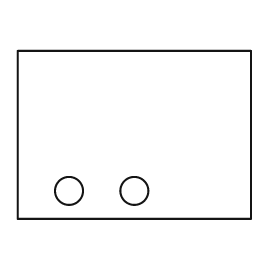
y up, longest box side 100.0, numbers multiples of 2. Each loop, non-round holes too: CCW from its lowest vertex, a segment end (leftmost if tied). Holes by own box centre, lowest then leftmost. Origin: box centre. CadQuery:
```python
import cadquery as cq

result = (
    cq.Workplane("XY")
    .moveTo(-50.0, -36.0)
    .lineTo(50.0, -36.0)
    .lineTo(50.0, 36.0)
    .lineTo(-50.0, 36.0)
    .close()
    .moveTo(-28.0, -24.0)
    .circle(6.0)
    .moveTo(0.0, -24.0)
    .circle(6.0)
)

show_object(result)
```